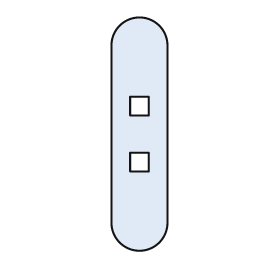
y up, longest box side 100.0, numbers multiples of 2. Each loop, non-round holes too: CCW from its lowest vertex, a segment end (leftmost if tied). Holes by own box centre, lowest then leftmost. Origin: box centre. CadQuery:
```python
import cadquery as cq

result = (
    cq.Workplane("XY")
    .moveTo(-12.0, -38.0)
    .threePointArc((0.0, -50.0), (12.0, -38.0))
    .lineTo(12.0, 38.0)
    .threePointArc((0.0, 50.0), (-12.0, 38.0))
    .close()
    .moveTo(-4.0, -16.0)
    .lineTo(4.0, -16.0)
    .lineTo(4.0, -8.0)
    .lineTo(-4.0, -8.0)
    .close()
    .moveTo(-4.0, 8.0)
    .lineTo(4.0, 8.0)
    .lineTo(4.0, 16.0)
    .lineTo(-4.0, 16.0)
    .close()
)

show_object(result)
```